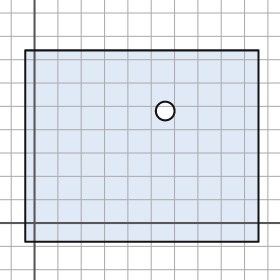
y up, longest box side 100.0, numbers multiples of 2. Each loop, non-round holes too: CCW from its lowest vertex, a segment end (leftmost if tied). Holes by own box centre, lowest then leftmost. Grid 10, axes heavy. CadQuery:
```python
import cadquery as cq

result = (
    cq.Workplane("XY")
    .moveTo(-4.0, -8.0)
    .lineTo(96.0, -8.0)
    .lineTo(96.0, 74.0)
    .lineTo(-4.0, 74.0)
    .close()
    .moveTo(56.0, 48.0)
    .circle(4.0)
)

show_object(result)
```